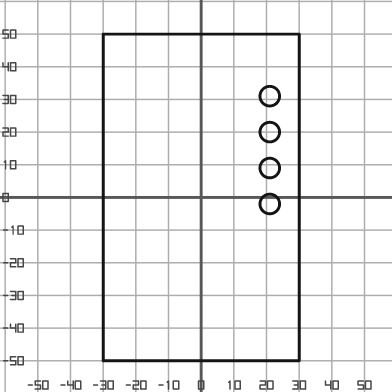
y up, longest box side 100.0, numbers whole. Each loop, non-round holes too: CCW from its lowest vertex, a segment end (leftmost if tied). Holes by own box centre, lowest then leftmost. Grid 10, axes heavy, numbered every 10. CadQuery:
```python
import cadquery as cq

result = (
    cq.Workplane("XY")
    .moveTo(-30.0, -50.0)
    .lineTo(30.0, -50.0)
    .lineTo(30.0, 50.0)
    .lineTo(-30.0, 50.0)
    .close()
    .moveTo(21.0, -2.0)
    .circle(3.0)
    .moveTo(21.0, 9.0)
    .circle(3.0)
    .moveTo(21.0, 20.0)
    .circle(3.0)
    .moveTo(21.0, 31.0)
    .circle(3.0)
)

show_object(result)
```